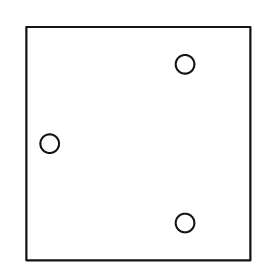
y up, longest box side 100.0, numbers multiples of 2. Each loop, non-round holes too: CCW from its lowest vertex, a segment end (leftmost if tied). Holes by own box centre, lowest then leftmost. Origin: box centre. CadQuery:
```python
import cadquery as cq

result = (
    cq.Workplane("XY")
    .moveTo(-48.0, -50.0)
    .lineTo(48.0, -50.0)
    .lineTo(48.0, 50.0)
    .lineTo(-48.0, 50.0)
    .close()
    .moveTo(20.0, -34.0)
    .circle(4.0)
    .moveTo(-38.0, 0.0)
    .circle(4.0)
    .moveTo(20.0, 34.0)
    .circle(4.0)
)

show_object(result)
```